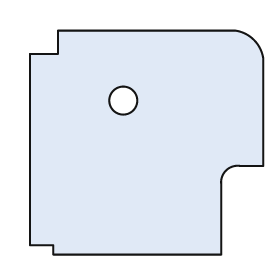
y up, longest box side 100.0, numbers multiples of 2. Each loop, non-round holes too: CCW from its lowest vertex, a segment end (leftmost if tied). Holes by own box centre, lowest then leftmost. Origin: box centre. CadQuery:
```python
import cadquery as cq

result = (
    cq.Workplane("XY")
    .moveTo(-40.0, -48.0)
    .lineTo(32.0, -48.0)
    .lineTo(32.0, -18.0)
    .threePointArc((34.0, -12.0), (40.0, -10.0))
    .lineTo(50.0, -10.0)
    .lineTo(50.0, 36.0)
    .threePointArc((46.0, 44.0), (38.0, 48.0))
    .lineTo(-38.0, 48.0)
    .lineTo(-38.0, 38.0)
    .lineTo(-50.0, 38.0)
    .lineTo(-50.0, -44.0)
    .lineTo(-40.0, -44.0)
    .close()
    .moveTo(-10.0, 18.0)
    .circle(6.0)
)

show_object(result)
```